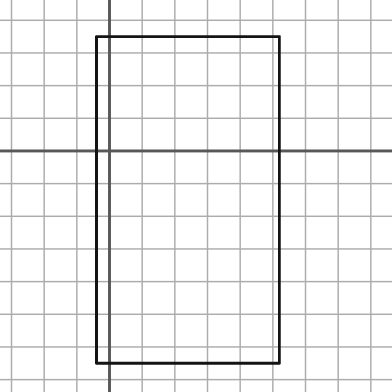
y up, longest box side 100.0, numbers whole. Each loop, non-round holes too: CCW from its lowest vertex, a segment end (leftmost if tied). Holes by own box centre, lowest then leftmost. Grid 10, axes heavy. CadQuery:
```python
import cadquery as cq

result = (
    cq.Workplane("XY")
    .moveTo(-4.0, -65.0)
    .lineTo(52.0, -65.0)
    .lineTo(52.0, 35.0)
    .lineTo(-4.0, 35.0)
    .close()
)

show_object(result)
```